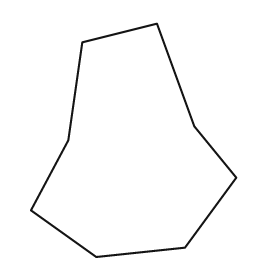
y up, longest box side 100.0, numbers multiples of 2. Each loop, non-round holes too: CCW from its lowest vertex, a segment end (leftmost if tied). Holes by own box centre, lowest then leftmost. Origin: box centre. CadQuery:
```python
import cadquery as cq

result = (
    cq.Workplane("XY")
    .moveTo(-16.0, -50.0)
    .lineTo(22.0, -46.0)
    .lineTo(44.0, -16.0)
    .lineTo(26.0, 6.0)
    .lineTo(10.0, 50.0)
    .lineTo(-22.0, 42.0)
    .lineTo(-28.0, 0.0)
    .lineTo(-44.0, -30.0)
    .close()
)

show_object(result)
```